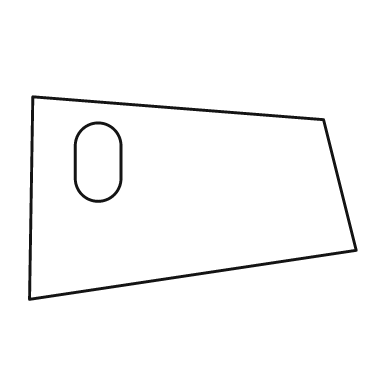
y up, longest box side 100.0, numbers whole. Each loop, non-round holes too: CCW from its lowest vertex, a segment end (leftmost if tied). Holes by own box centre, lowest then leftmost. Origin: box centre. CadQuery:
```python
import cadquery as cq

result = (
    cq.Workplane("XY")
    .moveTo(-50.0, -31.0)
    .lineTo(50.0, -16.0)
    .lineTo(40.0, 24.0)
    .lineTo(-49.0, 31.0)
    .close()
    .moveTo(-36.0, 6.0)
    .threePointArc((-29.0, -1.0), (-22.0, 6.0))
    .lineTo(-22.0, 16.0)
    .threePointArc((-29.0, 23.0), (-36.0, 16.0))
    .close()
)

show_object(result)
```